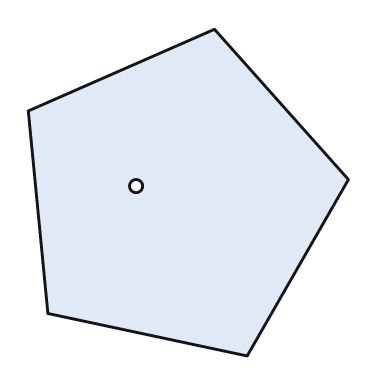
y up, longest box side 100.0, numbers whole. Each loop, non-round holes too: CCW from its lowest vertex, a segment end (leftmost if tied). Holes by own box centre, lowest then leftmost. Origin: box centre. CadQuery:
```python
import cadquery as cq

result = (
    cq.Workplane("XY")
    .moveTo(18.0, -50.0)
    .lineTo(49.0, 4.0)
    .lineTo(8.0, 50.0)
    .lineTo(-49.0, 25.0)
    .lineTo(-43.0, -37.0)
    .close()
    .moveTo(-16.0, 2.0)
    .circle(2.0)
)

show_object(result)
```